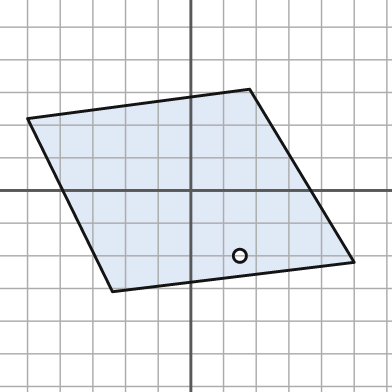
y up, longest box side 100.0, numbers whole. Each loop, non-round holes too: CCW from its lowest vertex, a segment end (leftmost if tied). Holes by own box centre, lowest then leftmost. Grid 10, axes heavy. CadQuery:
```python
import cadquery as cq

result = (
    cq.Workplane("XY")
    .moveTo(-24.0, -31.0)
    .lineTo(50.0, -22.0)
    .lineTo(18.0, 31.0)
    .lineTo(-50.0, 22.0)
    .close()
    .moveTo(15.0, -20.0)
    .circle(2.0)
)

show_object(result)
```